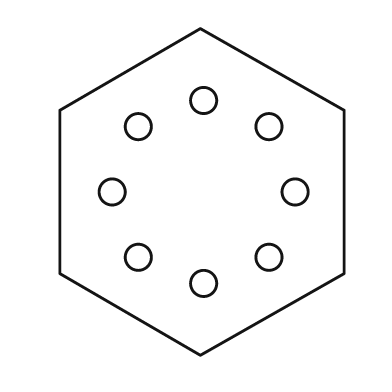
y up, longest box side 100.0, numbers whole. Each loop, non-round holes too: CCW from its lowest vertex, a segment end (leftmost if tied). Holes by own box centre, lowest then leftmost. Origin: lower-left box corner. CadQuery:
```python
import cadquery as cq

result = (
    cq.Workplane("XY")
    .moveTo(43.0, 0.0)
    .lineTo(87.0, 25.0)
    .lineTo(87.0, 75.0)
    .lineTo(43.0, 100.0)
    .lineTo(0.0, 75.0)
    .lineTo(0.0, 25.0)
    .close()
    .moveTo(44.0, 22.0)
    .circle(4.0)
    .moveTo(24.0, 30.0)
    .circle(4.0)
    .moveTo(64.0, 30.0)
    .circle(4.0)
    .moveTo(16.0, 50.0)
    .circle(4.0)
    .moveTo(72.0, 50.0)
    .circle(4.0)
    .moveTo(24.0, 70.0)
    .circle(4.0)
    .moveTo(64.0, 70.0)
    .circle(4.0)
    .moveTo(44.0, 78.0)
    .circle(4.0)
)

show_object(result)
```